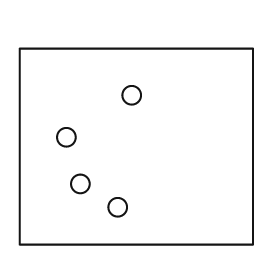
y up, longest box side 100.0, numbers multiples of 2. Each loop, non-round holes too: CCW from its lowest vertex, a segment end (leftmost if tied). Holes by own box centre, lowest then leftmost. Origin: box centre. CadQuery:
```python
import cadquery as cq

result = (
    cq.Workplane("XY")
    .moveTo(-50.0, -42.0)
    .lineTo(50.0, -42.0)
    .lineTo(50.0, 42.0)
    .lineTo(-50.0, 42.0)
    .close()
    .moveTo(-8.0, -26.0)
    .circle(4.0)
    .moveTo(-24.0, -16.0)
    .circle(4.0)
    .moveTo(-30.0, 4.0)
    .circle(4.0)
    .moveTo(-2.0, 22.0)
    .circle(4.0)
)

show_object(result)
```